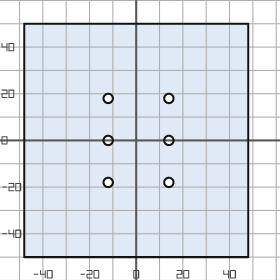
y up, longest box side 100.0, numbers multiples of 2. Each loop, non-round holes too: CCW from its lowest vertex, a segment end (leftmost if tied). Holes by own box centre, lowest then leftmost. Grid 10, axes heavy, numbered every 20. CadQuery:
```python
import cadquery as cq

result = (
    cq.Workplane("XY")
    .moveTo(-48.0, -50.0)
    .lineTo(48.0, -50.0)
    .lineTo(48.0, 50.0)
    .lineTo(-48.0, 50.0)
    .close()
    .moveTo(-12.0, -18.0)
    .circle(2.0)
    .moveTo(14.0, -18.0)
    .circle(2.0)
    .moveTo(-12.0, 0.0)
    .circle(2.0)
    .moveTo(14.0, 0.0)
    .circle(2.0)
    .moveTo(-12.0, 18.0)
    .circle(2.0)
    .moveTo(14.0, 18.0)
    .circle(2.0)
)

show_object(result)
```